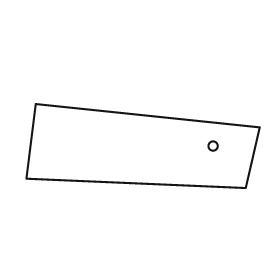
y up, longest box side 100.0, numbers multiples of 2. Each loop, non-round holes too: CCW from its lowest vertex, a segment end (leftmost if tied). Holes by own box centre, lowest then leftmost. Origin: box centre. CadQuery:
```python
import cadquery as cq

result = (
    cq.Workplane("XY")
    .moveTo(44.0, -18.0)
    .lineTo(50.0, 8.0)
    .lineTo(-46.0, 18.0)
    .lineTo(-50.0, -14.0)
    .close()
    .moveTo(30.0, 0.0)
    .circle(2.0)
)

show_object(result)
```